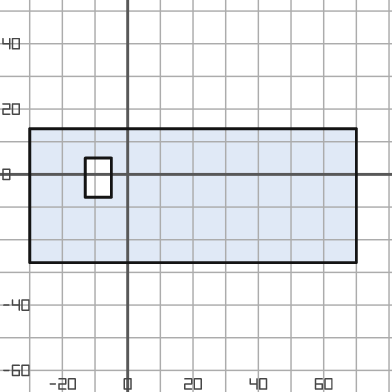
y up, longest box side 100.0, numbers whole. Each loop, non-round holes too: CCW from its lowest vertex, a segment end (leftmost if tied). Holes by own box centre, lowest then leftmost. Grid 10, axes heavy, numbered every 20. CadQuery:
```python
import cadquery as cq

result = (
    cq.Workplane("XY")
    .moveTo(-30.0, -27.0)
    .lineTo(70.0, -27.0)
    .lineTo(70.0, 14.0)
    .lineTo(-30.0, 14.0)
    .close()
    .moveTo(-13.0, -7.0)
    .lineTo(-5.0, -7.0)
    .lineTo(-5.0, 5.0)
    .lineTo(-13.0, 5.0)
    .close()
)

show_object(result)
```